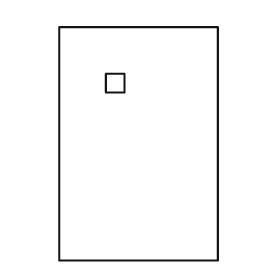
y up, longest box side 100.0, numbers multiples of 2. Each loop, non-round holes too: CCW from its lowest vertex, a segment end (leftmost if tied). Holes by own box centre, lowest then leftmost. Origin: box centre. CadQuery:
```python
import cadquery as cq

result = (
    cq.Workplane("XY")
    .moveTo(-34.0, -50.0)
    .lineTo(34.0, -50.0)
    .lineTo(34.0, 50.0)
    .lineTo(-34.0, 50.0)
    .close()
    .moveTo(-14.0, 22.0)
    .lineTo(-6.0, 22.0)
    .lineTo(-6.0, 30.0)
    .lineTo(-14.0, 30.0)
    .close()
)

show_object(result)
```